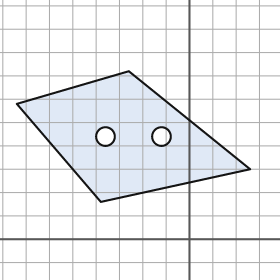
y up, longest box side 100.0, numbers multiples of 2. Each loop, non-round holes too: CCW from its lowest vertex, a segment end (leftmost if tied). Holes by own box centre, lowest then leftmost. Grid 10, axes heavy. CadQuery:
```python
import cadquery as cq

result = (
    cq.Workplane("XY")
    .moveTo(-38.0, 16.0)
    .lineTo(26.0, 30.0)
    .lineTo(-26.0, 72.0)
    .lineTo(-74.0, 58.0)
    .close()
    .moveTo(-36.0, 44.0)
    .circle(4.0)
    .moveTo(-12.0, 44.0)
    .circle(4.0)
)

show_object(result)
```